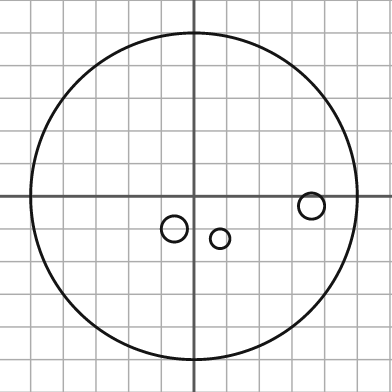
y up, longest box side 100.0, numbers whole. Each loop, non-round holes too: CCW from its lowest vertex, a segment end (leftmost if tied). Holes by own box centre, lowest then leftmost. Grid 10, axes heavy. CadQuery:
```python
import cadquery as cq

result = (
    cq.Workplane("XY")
    .moveTo(0.0, 0.0)
    .circle(50.0)
    .moveTo(8.0, -13.0)
    .circle(3.0)
    .moveTo(-6.0, -10.0)
    .circle(4.0)
    .moveTo(36.0, -3.0)
    .circle(4.0)
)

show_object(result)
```